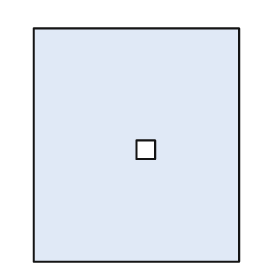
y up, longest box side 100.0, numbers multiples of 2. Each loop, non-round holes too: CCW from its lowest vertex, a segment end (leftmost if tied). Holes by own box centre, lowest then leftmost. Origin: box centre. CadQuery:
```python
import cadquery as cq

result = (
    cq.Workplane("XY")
    .moveTo(-44.0, -50.0)
    .lineTo(44.0, -50.0)
    .lineTo(44.0, 50.0)
    .lineTo(-44.0, 50.0)
    .close()
    .moveTo(0.0, -6.0)
    .lineTo(8.0, -6.0)
    .lineTo(8.0, 2.0)
    .lineTo(0.0, 2.0)
    .close()
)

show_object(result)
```